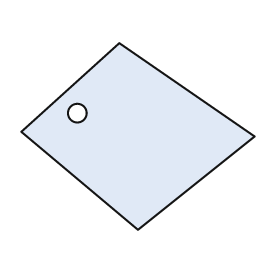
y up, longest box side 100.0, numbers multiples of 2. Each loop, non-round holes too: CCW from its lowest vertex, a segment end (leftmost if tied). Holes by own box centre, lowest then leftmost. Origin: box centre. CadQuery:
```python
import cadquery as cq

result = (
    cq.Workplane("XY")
    .moveTo(0.0, -40.0)
    .lineTo(50.0, 0.0)
    .lineTo(-8.0, 40.0)
    .lineTo(-50.0, 2.0)
    .close()
    .moveTo(-26.0, 10.0)
    .circle(4.0)
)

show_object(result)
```